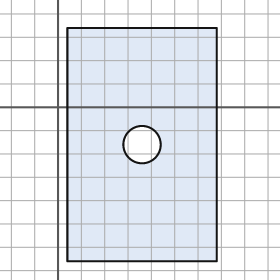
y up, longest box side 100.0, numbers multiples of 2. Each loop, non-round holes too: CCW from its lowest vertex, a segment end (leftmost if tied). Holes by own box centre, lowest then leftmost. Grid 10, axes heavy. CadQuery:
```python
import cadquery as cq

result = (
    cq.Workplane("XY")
    .moveTo(4.0, -66.0)
    .lineTo(68.0, -66.0)
    .lineTo(68.0, 34.0)
    .lineTo(4.0, 34.0)
    .close()
    .moveTo(36.0, -16.0)
    .circle(8.0)
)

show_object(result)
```